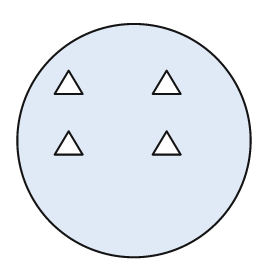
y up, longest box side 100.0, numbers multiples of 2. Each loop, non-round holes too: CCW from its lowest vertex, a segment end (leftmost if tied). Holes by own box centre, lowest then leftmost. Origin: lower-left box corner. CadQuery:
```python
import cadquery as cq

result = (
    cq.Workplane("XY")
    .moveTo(50.0, 50.0)
    .circle(50.0)
    .moveTo(16.0, 44.0)
    .lineTo(28.0, 44.0)
    .lineTo(22.0, 54.0)
    .close()
    .moveTo(58.0, 44.0)
    .lineTo(70.0, 44.0)
    .lineTo(64.0, 54.0)
    .close()
    .moveTo(16.0, 70.0)
    .lineTo(28.0, 70.0)
    .lineTo(22.0, 80.0)
    .close()
    .moveTo(58.0, 70.0)
    .lineTo(70.0, 70.0)
    .lineTo(64.0, 80.0)
    .close()
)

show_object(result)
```